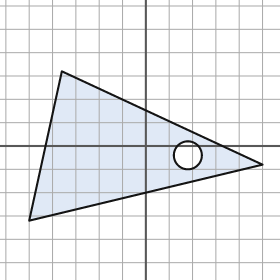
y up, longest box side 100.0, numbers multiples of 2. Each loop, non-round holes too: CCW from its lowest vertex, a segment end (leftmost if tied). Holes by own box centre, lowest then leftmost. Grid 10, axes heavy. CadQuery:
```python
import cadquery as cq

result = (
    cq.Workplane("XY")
    .moveTo(-50.0, -32.0)
    .lineTo(50.0, -8.0)
    .lineTo(-36.0, 32.0)
    .close()
    .moveTo(18.0, -4.0)
    .circle(6.0)
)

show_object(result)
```